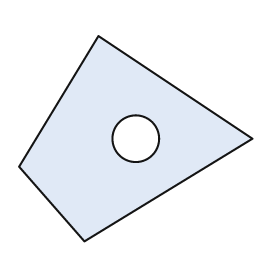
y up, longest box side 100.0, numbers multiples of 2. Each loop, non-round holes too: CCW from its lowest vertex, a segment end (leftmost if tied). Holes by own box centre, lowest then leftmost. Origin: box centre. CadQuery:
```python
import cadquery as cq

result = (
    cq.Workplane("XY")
    .moveTo(-22.0, -44.0)
    .lineTo(50.0, 0.0)
    .lineTo(-16.0, 44.0)
    .lineTo(-50.0, -12.0)
    .close()
    .moveTo(0.0, 0.0)
    .circle(10.0)
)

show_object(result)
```